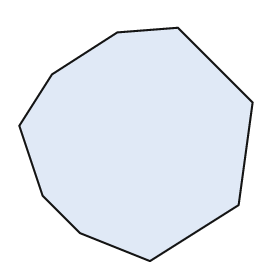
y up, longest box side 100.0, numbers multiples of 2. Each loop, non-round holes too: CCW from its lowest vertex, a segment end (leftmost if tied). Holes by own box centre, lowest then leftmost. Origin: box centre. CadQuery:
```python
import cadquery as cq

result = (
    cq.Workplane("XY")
    .moveTo(6.0, -50.0)
    .lineTo(44.0, -26.0)
    .lineTo(50.0, 18.0)
    .lineTo(18.0, 50.0)
    .lineTo(-8.0, 48.0)
    .lineTo(-36.0, 30.0)
    .lineTo(-50.0, 8.0)
    .lineTo(-40.0, -22.0)
    .lineTo(-24.0, -38.0)
    .close()
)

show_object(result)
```